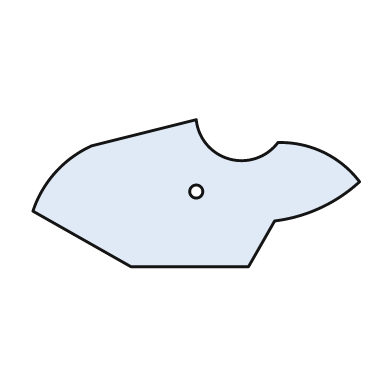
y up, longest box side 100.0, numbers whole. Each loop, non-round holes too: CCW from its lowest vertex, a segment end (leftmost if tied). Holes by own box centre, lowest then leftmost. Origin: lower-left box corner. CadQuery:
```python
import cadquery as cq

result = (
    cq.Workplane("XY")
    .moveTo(30.0, 0.0)
    .lineTo(66.0, 0.0)
    .lineTo(74.0, 14.0)
    .threePointArc((88.0, 18.0), (100.0, 26.0))
    .threePointArc((89.0, 35.0), (75.0, 38.0))
    .threePointArc((60.0, 33.0), (50.0, 45.0))
    .lineTo(18.0, 37.0)
    .threePointArc((7.0, 29.0), (0.0, 17.0))
    .close()
    .moveTo(50.0, 23.0)
    .circle(2.0)
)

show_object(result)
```